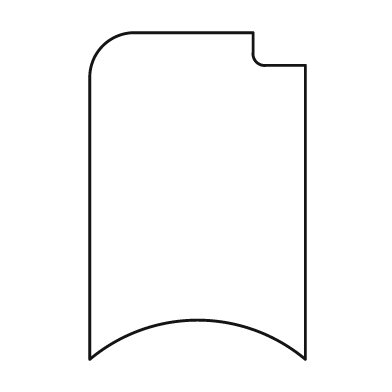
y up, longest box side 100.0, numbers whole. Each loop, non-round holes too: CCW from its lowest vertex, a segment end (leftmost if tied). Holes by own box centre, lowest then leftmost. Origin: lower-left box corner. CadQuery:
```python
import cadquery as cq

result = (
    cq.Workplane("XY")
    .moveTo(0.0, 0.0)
    .threePointArc((33.0, 12.0), (66.0, 0.0))
    .lineTo(66.0, 90.0)
    .lineTo(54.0, 90.0)
    .threePointArc((51.0, 91.0), (50.0, 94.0))
    .lineTo(50.0, 100.0)
    .lineTo(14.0, 100.0)
    .threePointArc((4.0, 96.0), (0.0, 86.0))
    .close()
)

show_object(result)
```